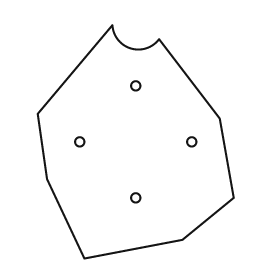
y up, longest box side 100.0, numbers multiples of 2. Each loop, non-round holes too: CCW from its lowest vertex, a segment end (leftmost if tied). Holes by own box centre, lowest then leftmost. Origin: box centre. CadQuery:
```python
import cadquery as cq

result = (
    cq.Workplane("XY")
    .moveTo(-22.0, -50.0)
    .lineTo(20.0, -42.0)
    .lineTo(42.0, -24.0)
    .lineTo(36.0, 10.0)
    .lineTo(10.0, 44.0)
    .threePointArc((-2.0, 40.0), (-10.0, 50.0))
    .lineTo(-42.0, 12.0)
    .lineTo(-38.0, -16.0)
    .close()
    .moveTo(0.0, -24.0)
    .circle(2.0)
    .moveTo(-24.0, 0.0)
    .circle(2.0)
    .moveTo(24.0, 0.0)
    .circle(2.0)
    .moveTo(0.0, 24.0)
    .circle(2.0)
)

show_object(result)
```